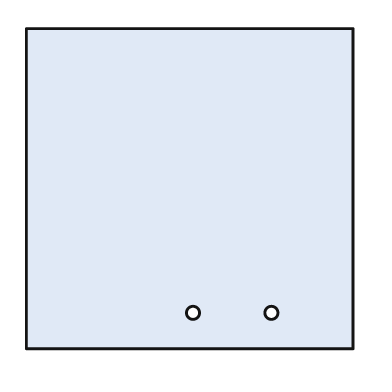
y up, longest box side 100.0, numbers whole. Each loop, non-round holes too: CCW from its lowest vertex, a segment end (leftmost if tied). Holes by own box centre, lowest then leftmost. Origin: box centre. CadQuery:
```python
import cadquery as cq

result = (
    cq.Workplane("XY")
    .moveTo(-50.0, -49.0)
    .lineTo(50.0, -49.0)
    .lineTo(50.0, 49.0)
    .lineTo(-50.0, 49.0)
    .close()
    .moveTo(1.0, -38.0)
    .circle(2.0)
    .moveTo(25.0, -38.0)
    .circle(2.0)
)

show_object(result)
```